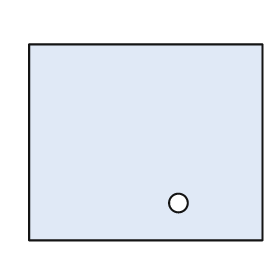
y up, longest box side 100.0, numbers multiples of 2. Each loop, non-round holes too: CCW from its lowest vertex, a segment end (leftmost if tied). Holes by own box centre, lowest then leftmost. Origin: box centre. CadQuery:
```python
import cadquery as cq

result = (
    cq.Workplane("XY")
    .moveTo(-50.0, -42.0)
    .lineTo(50.0, -42.0)
    .lineTo(50.0, 42.0)
    .lineTo(-50.0, 42.0)
    .close()
    .moveTo(14.0, -26.0)
    .circle(4.0)
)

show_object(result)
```